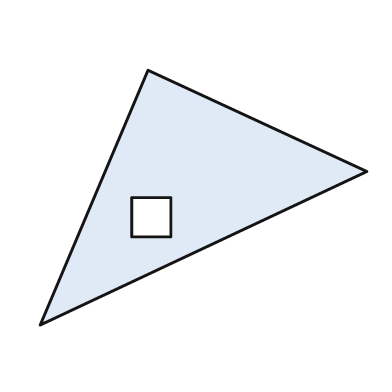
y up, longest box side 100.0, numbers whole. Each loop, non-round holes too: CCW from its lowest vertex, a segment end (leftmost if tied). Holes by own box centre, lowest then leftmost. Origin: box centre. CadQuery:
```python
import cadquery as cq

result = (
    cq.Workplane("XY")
    .moveTo(-50.0, -39.0)
    .lineTo(50.0, 8.0)
    .lineTo(-17.0, 39.0)
    .close()
    .moveTo(-22.0, -12.0)
    .lineTo(-10.0, -12.0)
    .lineTo(-10.0, 0.0)
    .lineTo(-22.0, 0.0)
    .close()
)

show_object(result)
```